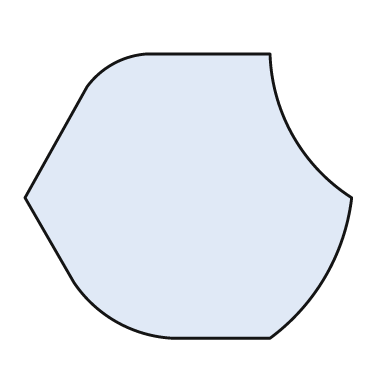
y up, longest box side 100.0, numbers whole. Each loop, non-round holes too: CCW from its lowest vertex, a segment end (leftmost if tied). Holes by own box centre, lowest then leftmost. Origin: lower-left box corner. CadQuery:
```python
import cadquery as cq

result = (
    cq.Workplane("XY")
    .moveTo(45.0, 0.0)
    .lineTo(75.0, 0.0)
    .threePointArc((92.0, 19.0), (100.0, 43.0))
    .threePointArc((82.0, 62.0), (75.0, 87.0))
    .lineTo(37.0, 87.0)
    .threePointArc((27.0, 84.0), (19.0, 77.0))
    .lineTo(0.0, 43.0)
    .lineTo(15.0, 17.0)
    .threePointArc((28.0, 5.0), (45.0, 0.0))
    .close()
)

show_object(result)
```